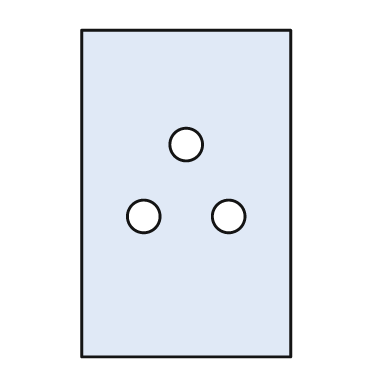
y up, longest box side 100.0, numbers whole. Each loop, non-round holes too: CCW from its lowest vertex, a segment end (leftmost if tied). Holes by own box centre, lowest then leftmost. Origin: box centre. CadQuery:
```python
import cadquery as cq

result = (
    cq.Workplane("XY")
    .moveTo(-32.0, -50.0)
    .lineTo(32.0, -50.0)
    .lineTo(32.0, 50.0)
    .lineTo(-32.0, 50.0)
    .close()
    .moveTo(-13.0, -7.0)
    .circle(5.0)
    .moveTo(13.0, -7.0)
    .circle(5.0)
    .moveTo(0.0, 15.0)
    .circle(5.0)
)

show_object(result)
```